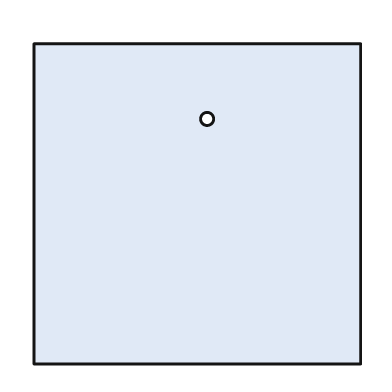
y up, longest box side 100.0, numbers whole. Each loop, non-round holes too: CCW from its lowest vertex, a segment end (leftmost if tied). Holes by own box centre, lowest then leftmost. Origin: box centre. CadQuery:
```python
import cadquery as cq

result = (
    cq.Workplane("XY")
    .moveTo(-50.0, -49.0)
    .lineTo(50.0, -49.0)
    .lineTo(50.0, 49.0)
    .lineTo(-50.0, 49.0)
    .close()
    .moveTo(3.0, 26.0)
    .circle(2.0)
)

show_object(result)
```